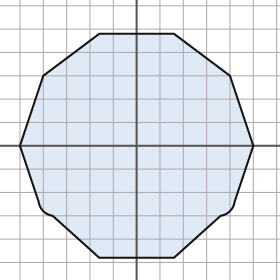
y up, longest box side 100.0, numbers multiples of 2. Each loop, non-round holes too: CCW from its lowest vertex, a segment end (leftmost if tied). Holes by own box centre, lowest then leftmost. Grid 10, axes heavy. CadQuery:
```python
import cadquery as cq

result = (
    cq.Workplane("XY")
    .moveTo(-16.0, -48.0)
    .lineTo(16.0, -48.0)
    .lineTo(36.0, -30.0)
    .threePointArc((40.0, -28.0), (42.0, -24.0))
    .lineTo(50.0, 0.0)
    .lineTo(40.0, 30.0)
    .lineTo(16.0, 48.0)
    .lineTo(-16.0, 48.0)
    .lineTo(-40.0, 30.0)
    .lineTo(-50.0, 0.0)
    .lineTo(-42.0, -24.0)
    .threePointArc((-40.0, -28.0), (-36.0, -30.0))
    .close()
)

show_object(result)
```